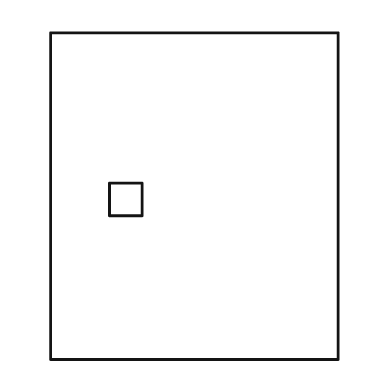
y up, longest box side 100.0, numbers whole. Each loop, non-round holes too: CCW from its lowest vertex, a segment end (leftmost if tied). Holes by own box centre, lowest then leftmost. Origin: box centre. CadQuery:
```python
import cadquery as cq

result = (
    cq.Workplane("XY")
    .moveTo(-44.0, -50.0)
    .lineTo(44.0, -50.0)
    .lineTo(44.0, 50.0)
    .lineTo(-44.0, 50.0)
    .close()
    .moveTo(-26.0, -6.0)
    .lineTo(-16.0, -6.0)
    .lineTo(-16.0, 4.0)
    .lineTo(-26.0, 4.0)
    .close()
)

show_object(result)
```